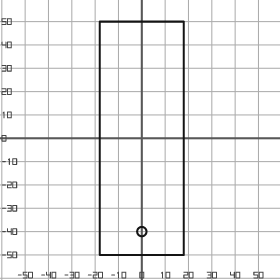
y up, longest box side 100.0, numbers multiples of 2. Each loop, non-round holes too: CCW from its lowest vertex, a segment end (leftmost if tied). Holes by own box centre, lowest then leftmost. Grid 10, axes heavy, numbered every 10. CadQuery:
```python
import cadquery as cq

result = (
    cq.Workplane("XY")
    .moveTo(-18.0, -50.0)
    .lineTo(18.0, -50.0)
    .lineTo(18.0, 50.0)
    .lineTo(-18.0, 50.0)
    .close()
    .moveTo(0.0, -40.0)
    .circle(2.0)
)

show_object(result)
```